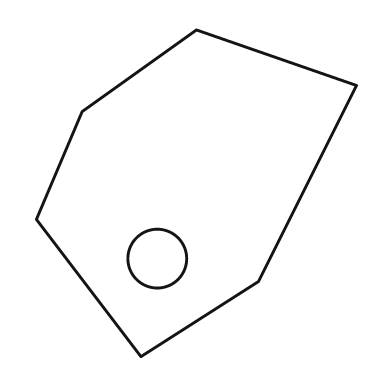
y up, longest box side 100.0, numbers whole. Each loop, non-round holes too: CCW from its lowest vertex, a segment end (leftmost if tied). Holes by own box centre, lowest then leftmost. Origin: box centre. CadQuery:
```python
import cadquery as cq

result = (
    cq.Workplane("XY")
    .moveTo(-17.0, -50.0)
    .lineTo(19.0, -27.0)
    .lineTo(49.0, 33.0)
    .lineTo(0.0, 50.0)
    .lineTo(-35.0, 25.0)
    .lineTo(-49.0, -8.0)
    .close()
    .moveTo(-12.0, -20.0)
    .circle(9.0)
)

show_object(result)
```